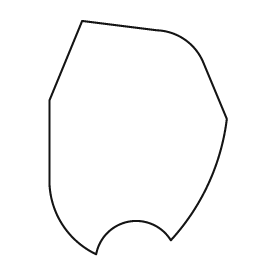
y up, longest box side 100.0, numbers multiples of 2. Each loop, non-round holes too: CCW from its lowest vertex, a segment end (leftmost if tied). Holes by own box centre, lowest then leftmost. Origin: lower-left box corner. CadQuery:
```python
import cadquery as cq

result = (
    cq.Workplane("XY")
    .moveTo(20.0, 0.0)
    .threePointArc((34.0, 14.0), (52.0, 6.0))
    .threePointArc((68.0, 30.0), (76.0, 58.0))
    .lineTo(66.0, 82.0)
    .threePointArc((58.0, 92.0), (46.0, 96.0))
    .lineTo(14.0, 100.0)
    .lineTo(0.0, 66.0)
    .lineTo(0.0, 30.0)
    .threePointArc((6.0, 12.0), (20.0, 0.0))
    .close()
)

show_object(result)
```